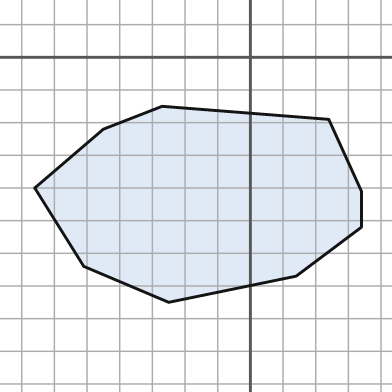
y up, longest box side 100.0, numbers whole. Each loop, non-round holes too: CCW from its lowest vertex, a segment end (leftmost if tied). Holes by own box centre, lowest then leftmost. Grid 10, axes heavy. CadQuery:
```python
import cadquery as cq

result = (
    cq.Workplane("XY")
    .moveTo(-25.0, -75.0)
    .lineTo(14.0, -67.0)
    .lineTo(34.0, -52.0)
    .lineTo(34.0, -41.0)
    .lineTo(24.0, -19.0)
    .lineTo(-27.0, -15.0)
    .lineTo(-45.0, -22.0)
    .lineTo(-66.0, -40.0)
    .lineTo(-51.0, -64.0)
    .close()
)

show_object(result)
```